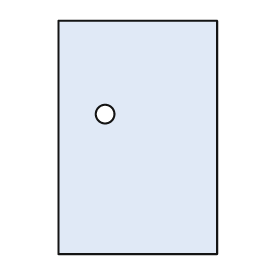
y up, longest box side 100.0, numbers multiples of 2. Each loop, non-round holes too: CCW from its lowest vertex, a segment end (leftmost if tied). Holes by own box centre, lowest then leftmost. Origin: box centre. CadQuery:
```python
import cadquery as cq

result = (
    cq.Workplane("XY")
    .moveTo(-34.0, -50.0)
    .lineTo(34.0, -50.0)
    .lineTo(34.0, 50.0)
    .lineTo(-34.0, 50.0)
    .close()
    .moveTo(-14.0, 10.0)
    .circle(4.0)
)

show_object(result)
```